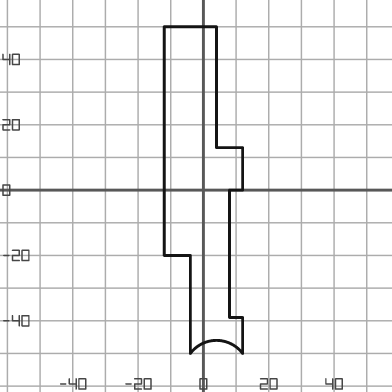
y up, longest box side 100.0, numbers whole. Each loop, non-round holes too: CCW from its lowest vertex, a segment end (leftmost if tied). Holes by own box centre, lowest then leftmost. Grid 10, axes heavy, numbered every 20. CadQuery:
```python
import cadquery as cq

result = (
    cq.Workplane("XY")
    .moveTo(-4.0, -50.0)
    .threePointArc((4.0, -46.0), (12.0, -50.0))
    .lineTo(12.0, -39.0)
    .lineTo(8.0, -39.0)
    .lineTo(8.0, 0.0)
    .lineTo(12.0, 0.0)
    .lineTo(12.0, 13.0)
    .lineTo(4.0, 13.0)
    .lineTo(4.0, 50.0)
    .lineTo(-12.0, 50.0)
    .lineTo(-12.0, -20.0)
    .lineTo(-4.0, -20.0)
    .close()
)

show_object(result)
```